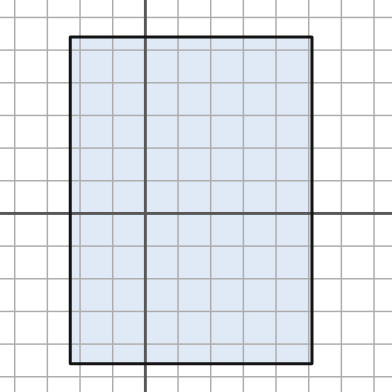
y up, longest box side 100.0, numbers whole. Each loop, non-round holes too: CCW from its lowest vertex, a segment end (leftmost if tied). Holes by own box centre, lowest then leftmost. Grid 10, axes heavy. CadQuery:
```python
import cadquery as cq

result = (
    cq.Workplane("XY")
    .moveTo(-23.0, -46.0)
    .lineTo(51.0, -46.0)
    .lineTo(51.0, 54.0)
    .lineTo(-23.0, 54.0)
    .close()
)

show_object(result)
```